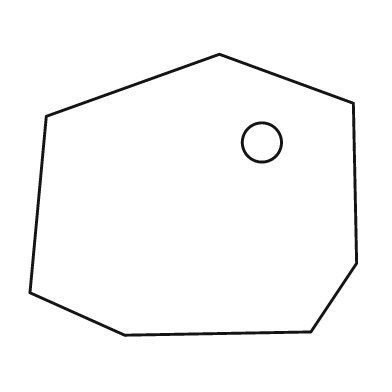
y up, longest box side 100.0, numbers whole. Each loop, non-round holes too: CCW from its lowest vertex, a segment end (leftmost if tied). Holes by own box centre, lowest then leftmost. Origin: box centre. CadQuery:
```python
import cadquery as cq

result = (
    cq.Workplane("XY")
    .moveTo(-21.0, -43.0)
    .lineTo(36.0, -42.0)
    .lineTo(50.0, -21.0)
    .lineTo(49.0, 28.0)
    .lineTo(8.0, 43.0)
    .lineTo(-45.0, 24.0)
    .lineTo(-50.0, -30.0)
    .close()
    .moveTo(21.0, 16.0)
    .circle(6.0)
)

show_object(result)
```